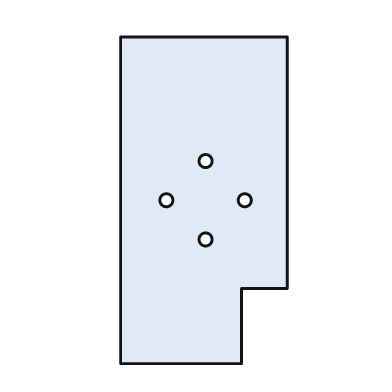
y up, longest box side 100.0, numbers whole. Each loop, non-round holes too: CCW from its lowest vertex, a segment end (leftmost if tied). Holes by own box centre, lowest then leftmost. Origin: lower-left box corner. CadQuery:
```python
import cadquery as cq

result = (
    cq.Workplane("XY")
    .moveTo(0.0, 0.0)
    .lineTo(37.0, 0.0)
    .lineTo(37.0, 23.0)
    .lineTo(51.0, 23.0)
    .lineTo(51.0, 100.0)
    .lineTo(0.0, 100.0)
    .close()
    .moveTo(26.0, 38.0)
    .circle(2.0)
    .moveTo(14.0, 50.0)
    .circle(2.0)
    .moveTo(38.0, 50.0)
    .circle(2.0)
    .moveTo(26.0, 62.0)
    .circle(2.0)
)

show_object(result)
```